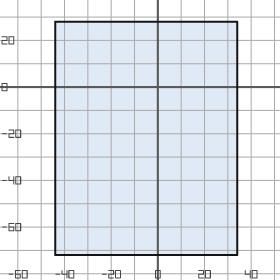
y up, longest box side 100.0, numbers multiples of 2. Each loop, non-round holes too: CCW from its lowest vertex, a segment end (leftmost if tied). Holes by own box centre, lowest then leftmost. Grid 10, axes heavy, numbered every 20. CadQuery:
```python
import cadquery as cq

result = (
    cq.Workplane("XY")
    .moveTo(-44.0, -72.0)
    .lineTo(34.0, -72.0)
    .lineTo(34.0, 28.0)
    .lineTo(-44.0, 28.0)
    .close()
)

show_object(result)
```